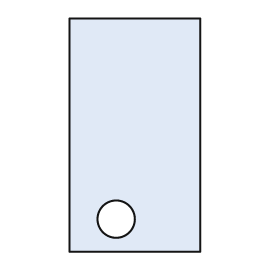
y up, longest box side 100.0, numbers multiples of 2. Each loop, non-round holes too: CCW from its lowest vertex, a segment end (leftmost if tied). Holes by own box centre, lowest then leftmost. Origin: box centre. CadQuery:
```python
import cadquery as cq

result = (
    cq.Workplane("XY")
    .moveTo(-28.0, -50.0)
    .lineTo(28.0, -50.0)
    .lineTo(28.0, 50.0)
    .lineTo(-28.0, 50.0)
    .close()
    .moveTo(-8.0, -36.0)
    .circle(8.0)
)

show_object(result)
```